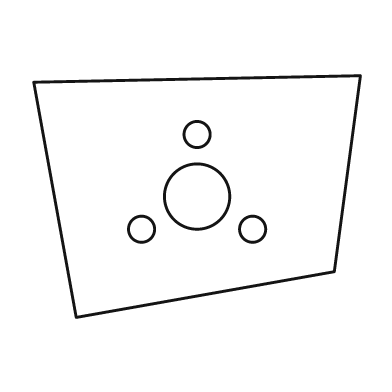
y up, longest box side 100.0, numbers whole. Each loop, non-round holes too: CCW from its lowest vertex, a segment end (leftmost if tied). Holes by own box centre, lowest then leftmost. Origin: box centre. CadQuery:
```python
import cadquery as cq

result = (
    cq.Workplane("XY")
    .moveTo(-37.0, -37.0)
    .lineTo(42.0, -23.0)
    .lineTo(50.0, 37.0)
    .lineTo(-50.0, 35.0)
    .close()
    .moveTo(-17.0, -10.0)
    .circle(4.0)
    .moveTo(17.0, -10.0)
    .circle(4.0)
    .moveTo(0.0, 0.0)
    .circle(10.0)
    .moveTo(0.0, 19.0)
    .circle(4.0)
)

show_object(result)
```